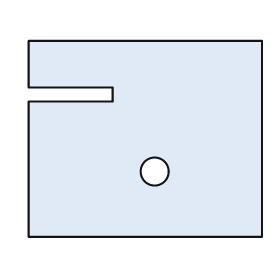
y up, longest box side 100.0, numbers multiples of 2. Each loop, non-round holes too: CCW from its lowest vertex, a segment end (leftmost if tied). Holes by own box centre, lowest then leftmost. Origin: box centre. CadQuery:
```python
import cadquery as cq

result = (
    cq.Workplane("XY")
    .moveTo(-50.0, -42.0)
    .lineTo(50.0, -42.0)
    .lineTo(50.0, 42.0)
    .lineTo(-50.0, 42.0)
    .lineTo(-50.0, 22.0)
    .lineTo(-14.0, 22.0)
    .lineTo(-14.0, 16.0)
    .lineTo(-50.0, 16.0)
    .close()
    .moveTo(4.0, -14.0)
    .circle(6.0)
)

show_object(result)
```